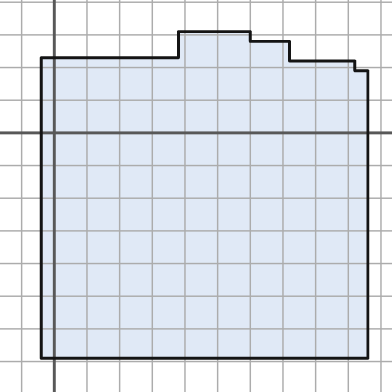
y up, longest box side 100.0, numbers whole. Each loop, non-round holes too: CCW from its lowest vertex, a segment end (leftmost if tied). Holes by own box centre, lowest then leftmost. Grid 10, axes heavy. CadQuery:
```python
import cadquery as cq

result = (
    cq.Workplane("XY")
    .moveTo(-4.0, -69.0)
    .lineTo(96.0, -69.0)
    .lineTo(96.0, 19.0)
    .lineTo(92.0, 19.0)
    .lineTo(92.0, 22.0)
    .lineTo(72.0, 22.0)
    .lineTo(72.0, 28.0)
    .lineTo(60.0, 28.0)
    .lineTo(60.0, 31.0)
    .lineTo(38.0, 31.0)
    .lineTo(38.0, 23.0)
    .lineTo(-4.0, 23.0)
    .close()
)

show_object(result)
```